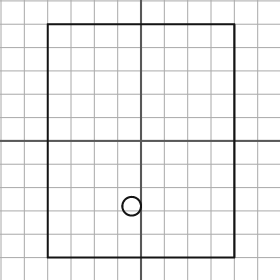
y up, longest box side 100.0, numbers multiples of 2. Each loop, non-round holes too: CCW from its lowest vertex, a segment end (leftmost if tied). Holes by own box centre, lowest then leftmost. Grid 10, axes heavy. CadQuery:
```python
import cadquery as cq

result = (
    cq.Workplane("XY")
    .moveTo(-40.0, -50.0)
    .lineTo(40.0, -50.0)
    .lineTo(40.0, 50.0)
    .lineTo(-40.0, 50.0)
    .close()
    .moveTo(-4.0, -28.0)
    .circle(4.0)
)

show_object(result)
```